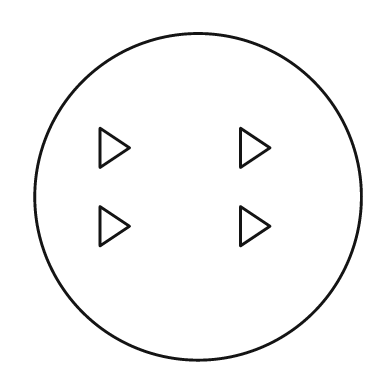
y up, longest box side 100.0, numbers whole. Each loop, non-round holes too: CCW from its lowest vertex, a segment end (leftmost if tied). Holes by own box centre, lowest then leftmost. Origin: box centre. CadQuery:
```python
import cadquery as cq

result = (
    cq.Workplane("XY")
    .moveTo(0.0, 0.0)
    .circle(50.0)
    .moveTo(-30.0, -15.0)
    .lineTo(-21.0, -9.0)
    .lineTo(-30.0, -3.0)
    .close()
    .moveTo(13.0, -15.0)
    .lineTo(22.0, -9.0)
    .lineTo(13.0, -3.0)
    .close()
    .moveTo(-30.0, 9.0)
    .lineTo(-21.0, 15.0)
    .lineTo(-30.0, 21.0)
    .close()
    .moveTo(13.0, 9.0)
    .lineTo(22.0, 15.0)
    .lineTo(13.0, 21.0)
    .close()
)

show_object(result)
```